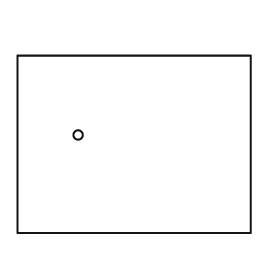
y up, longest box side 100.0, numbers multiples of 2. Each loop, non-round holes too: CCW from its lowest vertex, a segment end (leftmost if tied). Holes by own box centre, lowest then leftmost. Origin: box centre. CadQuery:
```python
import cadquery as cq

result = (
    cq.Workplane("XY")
    .moveTo(-50.0, -38.0)
    .lineTo(50.0, -38.0)
    .lineTo(50.0, 38.0)
    .lineTo(-50.0, 38.0)
    .close()
    .moveTo(-24.0, 4.0)
    .circle(2.0)
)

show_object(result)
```